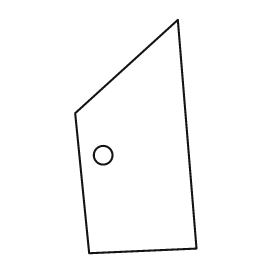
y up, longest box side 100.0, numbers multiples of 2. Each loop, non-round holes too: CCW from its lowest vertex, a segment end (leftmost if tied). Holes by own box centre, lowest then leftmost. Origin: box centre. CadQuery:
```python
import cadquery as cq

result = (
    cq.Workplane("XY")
    .moveTo(-20.0, -50.0)
    .lineTo(26.0, -48.0)
    .lineTo(18.0, 50.0)
    .lineTo(-26.0, 10.0)
    .close()
    .moveTo(-14.0, -8.0)
    .circle(4.0)
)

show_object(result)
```